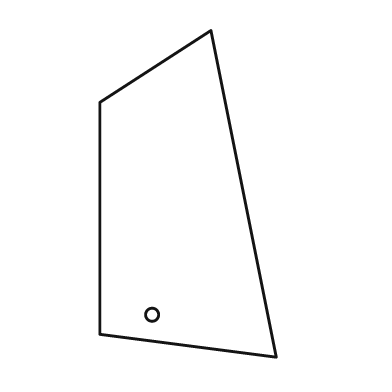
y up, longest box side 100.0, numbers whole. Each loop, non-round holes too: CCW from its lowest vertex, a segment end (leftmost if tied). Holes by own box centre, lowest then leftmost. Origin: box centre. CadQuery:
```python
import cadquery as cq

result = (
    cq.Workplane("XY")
    .moveTo(27.0, -50.0)
    .lineTo(7.0, 50.0)
    .lineTo(-27.0, 28.0)
    .lineTo(-27.0, -43.0)
    .close()
    .moveTo(-11.0, -37.0)
    .circle(2.0)
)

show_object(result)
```